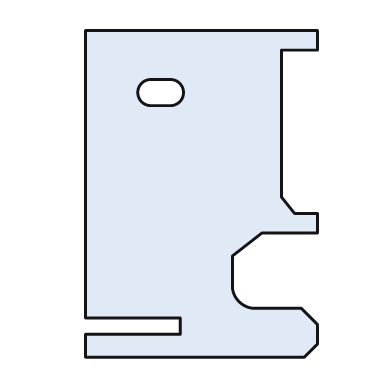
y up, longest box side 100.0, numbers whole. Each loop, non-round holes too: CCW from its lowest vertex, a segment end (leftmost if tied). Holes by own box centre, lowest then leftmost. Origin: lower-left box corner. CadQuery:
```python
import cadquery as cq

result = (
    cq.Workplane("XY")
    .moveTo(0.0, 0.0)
    .lineTo(67.0, 0.0)
    .lineTo(71.0, 4.0)
    .lineTo(71.0, 10.0)
    .lineTo(66.0, 15.0)
    .lineTo(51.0, 15.0)
    .threePointArc((47.0, 17.0), (45.0, 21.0))
    .lineTo(45.0, 31.0)
    .lineTo(54.0, 38.0)
    .lineTo(71.0, 38.0)
    .lineTo(71.0, 44.0)
    .lineTo(64.0, 44.0)
    .lineTo(60.0, 49.0)
    .lineTo(60.0, 94.0)
    .lineTo(71.0, 94.0)
    .lineTo(71.0, 100.0)
    .lineTo(0.0, 100.0)
    .lineTo(0.0, 12.0)
    .lineTo(29.0, 12.0)
    .lineTo(29.0, 7.0)
    .lineTo(0.0, 7.0)
    .close()
    .moveTo(20.0, 77.0)
    .lineTo(26.0, 77.0)
    .threePointArc((30.0, 81.0), (26.0, 85.0))
    .lineTo(20.0, 85.0)
    .threePointArc((16.0, 81.0), (20.0, 77.0))
    .close()
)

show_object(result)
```